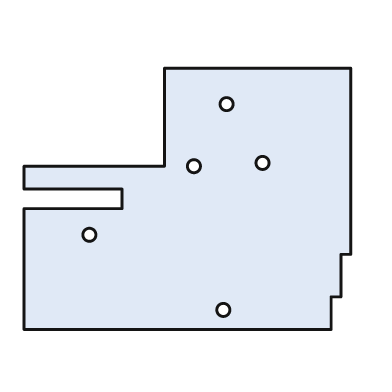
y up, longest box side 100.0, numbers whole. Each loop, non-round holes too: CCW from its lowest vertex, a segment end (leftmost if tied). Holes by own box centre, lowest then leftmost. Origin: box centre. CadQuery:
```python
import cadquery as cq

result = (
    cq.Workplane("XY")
    .moveTo(-50.0, -40.0)
    .lineTo(44.0, -40.0)
    .lineTo(44.0, -30.0)
    .lineTo(47.0, -30.0)
    .lineTo(47.0, -17.0)
    .lineTo(50.0, -17.0)
    .lineTo(50.0, 40.0)
    .lineTo(-7.0, 40.0)
    .lineTo(-7.0, 10.0)
    .lineTo(-50.0, 10.0)
    .lineTo(-50.0, 3.0)
    .lineTo(-20.0, 3.0)
    .lineTo(-20.0, -3.0)
    .lineTo(-50.0, -3.0)
    .close()
    .moveTo(11.0, -34.0)
    .circle(2.0)
    .moveTo(-30.0, -11.0)
    .circle(2.0)
    .moveTo(2.0, 10.0)
    .circle(2.0)
    .moveTo(23.0, 11.0)
    .circle(2.0)
    .moveTo(12.0, 29.0)
    .circle(2.0)
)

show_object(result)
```